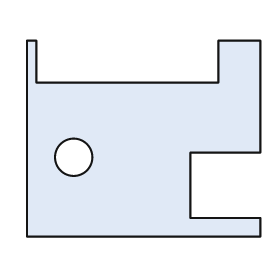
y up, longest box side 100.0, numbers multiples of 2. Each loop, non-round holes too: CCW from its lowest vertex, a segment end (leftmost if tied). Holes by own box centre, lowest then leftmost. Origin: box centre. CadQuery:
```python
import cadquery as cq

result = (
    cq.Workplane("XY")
    .moveTo(-50.0, -42.0)
    .lineTo(50.0, -42.0)
    .lineTo(50.0, -34.0)
    .lineTo(20.0, -34.0)
    .lineTo(20.0, -6.0)
    .lineTo(50.0, -6.0)
    .lineTo(50.0, 42.0)
    .lineTo(32.0, 42.0)
    .lineTo(32.0, 24.0)
    .lineTo(-46.0, 24.0)
    .lineTo(-46.0, 42.0)
    .lineTo(-50.0, 42.0)
    .close()
    .moveTo(-30.0, -8.0)
    .circle(8.0)
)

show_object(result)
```